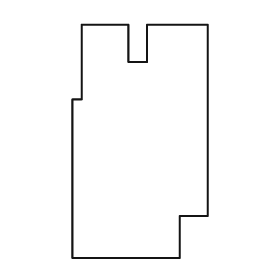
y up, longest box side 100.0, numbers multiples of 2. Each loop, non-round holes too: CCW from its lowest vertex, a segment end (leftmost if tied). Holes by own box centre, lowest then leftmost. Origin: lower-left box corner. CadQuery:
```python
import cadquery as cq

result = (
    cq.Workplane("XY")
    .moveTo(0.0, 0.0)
    .lineTo(46.0, 0.0)
    .lineTo(46.0, 18.0)
    .lineTo(58.0, 18.0)
    .lineTo(58.0, 100.0)
    .lineTo(32.0, 100.0)
    .lineTo(32.0, 84.0)
    .lineTo(24.0, 84.0)
    .lineTo(24.0, 100.0)
    .lineTo(4.0, 100.0)
    .lineTo(4.0, 68.0)
    .lineTo(0.0, 68.0)
    .close()
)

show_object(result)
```